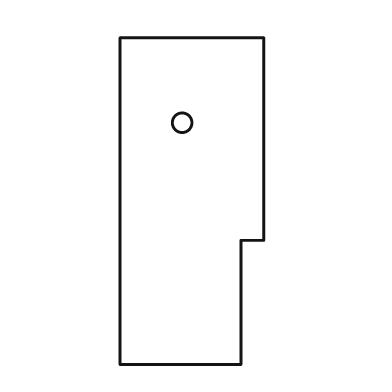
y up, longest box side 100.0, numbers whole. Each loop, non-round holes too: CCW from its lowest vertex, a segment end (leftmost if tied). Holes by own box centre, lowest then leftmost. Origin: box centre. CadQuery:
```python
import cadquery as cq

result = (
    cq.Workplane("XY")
    .moveTo(-22.0, -50.0)
    .lineTo(15.0, -50.0)
    .lineTo(15.0, -12.0)
    .lineTo(22.0, -12.0)
    .lineTo(22.0, 50.0)
    .lineTo(-22.0, 50.0)
    .close()
    .moveTo(-3.0, 24.0)
    .circle(3.0)
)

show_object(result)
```